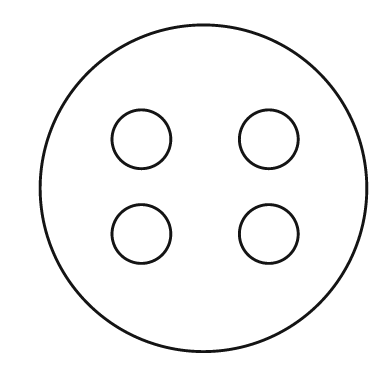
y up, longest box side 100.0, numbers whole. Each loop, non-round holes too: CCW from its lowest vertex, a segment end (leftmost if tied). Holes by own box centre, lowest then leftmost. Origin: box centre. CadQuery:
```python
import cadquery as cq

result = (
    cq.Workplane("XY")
    .moveTo(0.0, 0.0)
    .circle(50.0)
    .moveTo(-19.0, -14.0)
    .circle(9.0)
    .moveTo(20.0, -14.0)
    .circle(9.0)
    .moveTo(-19.0, 15.0)
    .circle(9.0)
    .moveTo(20.0, 15.0)
    .circle(9.0)
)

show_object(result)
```